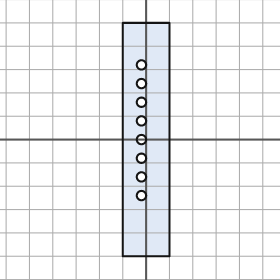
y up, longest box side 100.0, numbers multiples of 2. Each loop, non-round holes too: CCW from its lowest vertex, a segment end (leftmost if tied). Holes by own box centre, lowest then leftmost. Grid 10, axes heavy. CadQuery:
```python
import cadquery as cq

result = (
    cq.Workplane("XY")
    .moveTo(-10.0, -50.0)
    .lineTo(10.0, -50.0)
    .lineTo(10.0, 50.0)
    .lineTo(-10.0, 50.0)
    .close()
    .moveTo(-2.0, -24.0)
    .circle(2.0)
    .moveTo(-2.0, -16.0)
    .circle(2.0)
    .moveTo(-2.0, -8.0)
    .circle(2.0)
    .moveTo(-2.0, 0.0)
    .circle(2.0)
    .moveTo(-2.0, 8.0)
    .circle(2.0)
    .moveTo(-2.0, 16.0)
    .circle(2.0)
    .moveTo(-2.0, 24.0)
    .circle(2.0)
    .moveTo(-2.0, 32.0)
    .circle(2.0)
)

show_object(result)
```